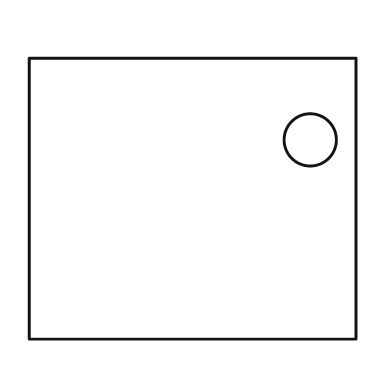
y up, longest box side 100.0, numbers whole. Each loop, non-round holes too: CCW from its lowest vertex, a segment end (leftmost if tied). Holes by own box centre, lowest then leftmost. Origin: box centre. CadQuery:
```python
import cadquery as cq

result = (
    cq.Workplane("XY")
    .moveTo(-50.0, -43.0)
    .lineTo(50.0, -43.0)
    .lineTo(50.0, 43.0)
    .lineTo(-50.0, 43.0)
    .close()
    .moveTo(36.0, 18.0)
    .circle(8.0)
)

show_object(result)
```